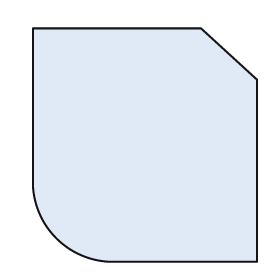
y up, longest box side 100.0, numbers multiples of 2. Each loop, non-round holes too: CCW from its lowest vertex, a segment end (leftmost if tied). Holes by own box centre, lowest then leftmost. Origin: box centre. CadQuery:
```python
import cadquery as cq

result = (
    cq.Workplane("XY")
    .moveTo(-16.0, -50.0)
    .lineTo(48.0, -50.0)
    .lineTo(48.0, 28.0)
    .lineTo(24.0, 50.0)
    .lineTo(-48.0, 50.0)
    .lineTo(-48.0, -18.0)
    .threePointArc((-38.0, -40.0), (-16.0, -50.0))
    .close()
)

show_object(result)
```